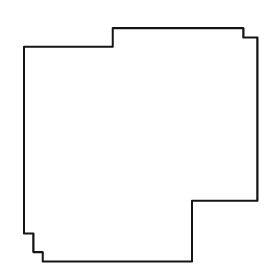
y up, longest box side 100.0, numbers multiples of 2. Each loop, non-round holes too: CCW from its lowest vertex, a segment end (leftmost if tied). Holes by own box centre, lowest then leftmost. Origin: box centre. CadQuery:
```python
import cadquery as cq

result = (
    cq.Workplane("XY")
    .moveTo(-42.0, -50.0)
    .lineTo(22.0, -50.0)
    .lineTo(22.0, -24.0)
    .lineTo(50.0, -24.0)
    .lineTo(50.0, 46.0)
    .lineTo(44.0, 46.0)
    .lineTo(44.0, 50.0)
    .lineTo(-12.0, 50.0)
    .lineTo(-12.0, 42.0)
    .lineTo(-50.0, 42.0)
    .lineTo(-50.0, -38.0)
    .lineTo(-46.0, -38.0)
    .lineTo(-46.0, -46.0)
    .lineTo(-42.0, -46.0)
    .close()
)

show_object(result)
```